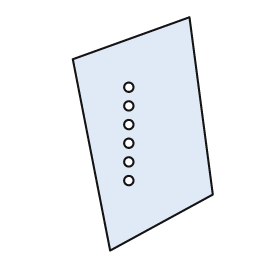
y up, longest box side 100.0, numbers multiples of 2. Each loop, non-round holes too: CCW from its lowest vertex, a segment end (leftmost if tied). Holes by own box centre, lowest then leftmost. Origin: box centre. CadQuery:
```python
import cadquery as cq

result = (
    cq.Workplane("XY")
    .moveTo(-14.0, -50.0)
    .lineTo(30.0, -26.0)
    .lineTo(20.0, 50.0)
    .lineTo(-30.0, 32.0)
    .close()
    .moveTo(-6.0, -20.0)
    .circle(2.0)
    .moveTo(-6.0, -12.0)
    .circle(2.0)
    .moveTo(-6.0, -4.0)
    .circle(2.0)
    .moveTo(-6.0, 4.0)
    .circle(2.0)
    .moveTo(-6.0, 12.0)
    .circle(2.0)
    .moveTo(-6.0, 20.0)
    .circle(2.0)
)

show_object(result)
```